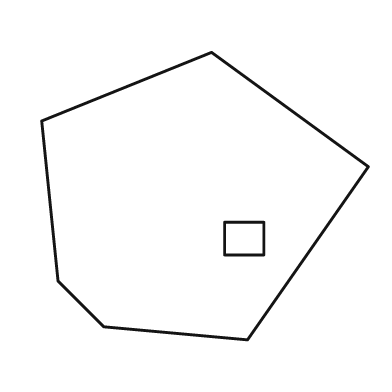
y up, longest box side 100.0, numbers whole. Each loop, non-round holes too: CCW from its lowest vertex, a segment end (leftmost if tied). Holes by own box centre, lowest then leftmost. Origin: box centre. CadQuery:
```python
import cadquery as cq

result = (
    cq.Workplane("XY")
    .moveTo(13.0, -44.0)
    .lineTo(50.0, 9.0)
    .lineTo(2.0, 44.0)
    .lineTo(-50.0, 23.0)
    .lineTo(-45.0, -26.0)
    .lineTo(-31.0, -40.0)
    .close()
    .moveTo(6.0, -18.0)
    .lineTo(18.0, -18.0)
    .lineTo(18.0, -8.0)
    .lineTo(6.0, -8.0)
    .close()
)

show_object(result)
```